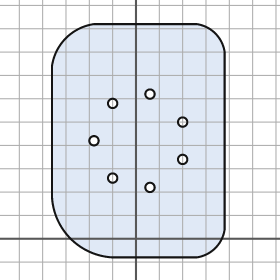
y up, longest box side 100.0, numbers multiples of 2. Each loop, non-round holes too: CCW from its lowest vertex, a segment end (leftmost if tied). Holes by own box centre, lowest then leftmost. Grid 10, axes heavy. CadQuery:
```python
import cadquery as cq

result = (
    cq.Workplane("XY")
    .moveTo(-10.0, -8.0)
    .lineTo(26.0, -8.0)
    .threePointArc((34.0, -4.0), (38.0, 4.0))
    .lineTo(38.0, 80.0)
    .threePointArc((34.0, 88.0), (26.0, 92.0))
    .lineTo(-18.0, 92.0)
    .threePointArc((-30.0, 86.0), (-36.0, 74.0))
    .lineTo(-36.0, 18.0)
    .threePointArc((-28.0, 0.0), (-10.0, -8.0))
    .close()
    .moveTo(6.0, 22.0)
    .circle(2.0)
    .moveTo(-10.0, 26.0)
    .circle(2.0)
    .moveTo(20.0, 34.0)
    .circle(2.0)
    .moveTo(-18.0, 42.0)
    .circle(2.0)
    .moveTo(20.0, 50.0)
    .circle(2.0)
    .moveTo(-10.0, 58.0)
    .circle(2.0)
    .moveTo(6.0, 62.0)
    .circle(2.0)
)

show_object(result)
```